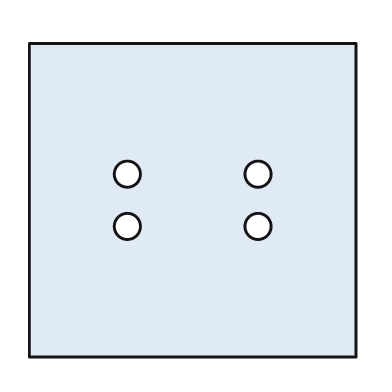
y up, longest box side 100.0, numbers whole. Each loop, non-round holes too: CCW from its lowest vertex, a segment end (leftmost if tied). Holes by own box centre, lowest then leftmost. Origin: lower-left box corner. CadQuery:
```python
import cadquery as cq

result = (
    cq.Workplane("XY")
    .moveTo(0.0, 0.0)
    .lineTo(100.0, 0.0)
    .lineTo(100.0, 96.0)
    .lineTo(0.0, 96.0)
    .close()
    .moveTo(30.0, 40.0)
    .circle(4.0)
    .moveTo(70.0, 40.0)
    .circle(4.0)
    .moveTo(30.0, 56.0)
    .circle(4.0)
    .moveTo(70.0, 56.0)
    .circle(4.0)
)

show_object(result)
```